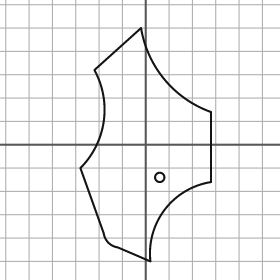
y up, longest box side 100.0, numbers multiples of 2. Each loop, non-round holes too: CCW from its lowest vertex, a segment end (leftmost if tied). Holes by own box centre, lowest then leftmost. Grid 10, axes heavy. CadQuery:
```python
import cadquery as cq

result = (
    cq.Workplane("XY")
    .moveTo(2.0, -50.0)
    .threePointArc((8.0, -28.0), (28.0, -16.0))
    .lineTo(28.0, 14.0)
    .threePointArc((8.0, 28.0), (-2.0, 50.0))
    .lineTo(-22.0, 32.0)
    .threePointArc((-18.0, 10.0), (-28.0, -10.0))
    .lineTo(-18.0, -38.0)
    .threePointArc((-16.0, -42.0), (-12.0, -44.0))
    .close()
    .moveTo(6.0, -14.0)
    .circle(2.0)
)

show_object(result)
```